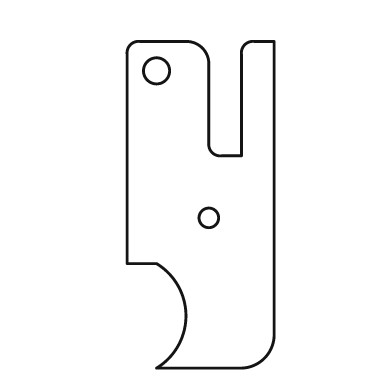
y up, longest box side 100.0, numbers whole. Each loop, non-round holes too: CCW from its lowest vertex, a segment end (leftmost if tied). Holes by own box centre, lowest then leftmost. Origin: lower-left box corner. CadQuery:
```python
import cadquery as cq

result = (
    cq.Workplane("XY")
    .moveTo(9.0, 0.0)
    .lineTo(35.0, 0.0)
    .threePointArc((42.0, 3.0), (45.0, 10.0))
    .lineTo(45.0, 100.0)
    .lineTo(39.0, 100.0)
    .threePointArc((36.0, 99.0), (35.0, 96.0))
    .lineTo(35.0, 65.0)
    .lineTo(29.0, 65.0)
    .threePointArc((26.0, 66.0), (25.0, 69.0))
    .lineTo(25.0, 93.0)
    .threePointArc((23.0, 98.0), (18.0, 100.0))
    .lineTo(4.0, 100.0)
    .threePointArc((1.0, 99.0), (0.0, 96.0))
    .lineTo(0.0, 32.0)
    .lineTo(9.0, 32.0)
    .threePointArc((18.0, 16.0), (9.0, 0.0))
    .close()
    .moveTo(25.0, 46.0)
    .circle(3.0)
    .moveTo(9.0, 91.0)
    .circle(4.0)
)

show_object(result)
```